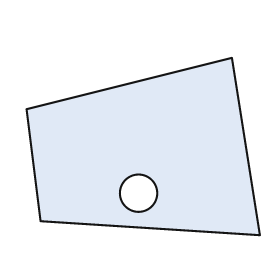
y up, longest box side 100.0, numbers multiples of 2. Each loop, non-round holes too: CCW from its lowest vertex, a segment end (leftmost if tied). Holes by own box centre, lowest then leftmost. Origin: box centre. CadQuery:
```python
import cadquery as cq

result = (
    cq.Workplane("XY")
    .moveTo(50.0, -38.0)
    .lineTo(38.0, 38.0)
    .lineTo(-50.0, 16.0)
    .lineTo(-44.0, -32.0)
    .close()
    .moveTo(-2.0, -20.0)
    .circle(8.0)
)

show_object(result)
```